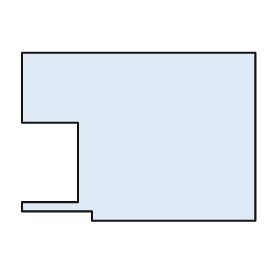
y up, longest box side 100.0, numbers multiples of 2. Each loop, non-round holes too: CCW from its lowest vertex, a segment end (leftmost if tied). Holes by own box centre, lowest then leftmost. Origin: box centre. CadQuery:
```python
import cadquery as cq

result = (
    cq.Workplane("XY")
    .moveTo(-20.0, -36.0)
    .lineTo(50.0, -36.0)
    .lineTo(50.0, 36.0)
    .lineTo(-50.0, 36.0)
    .lineTo(-50.0, 6.0)
    .lineTo(-26.0, 6.0)
    .lineTo(-26.0, -28.0)
    .lineTo(-50.0, -28.0)
    .lineTo(-50.0, -32.0)
    .lineTo(-20.0, -32.0)
    .close()
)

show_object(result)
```